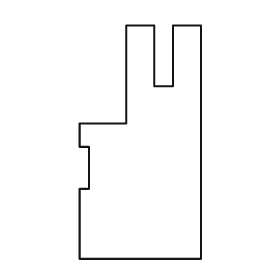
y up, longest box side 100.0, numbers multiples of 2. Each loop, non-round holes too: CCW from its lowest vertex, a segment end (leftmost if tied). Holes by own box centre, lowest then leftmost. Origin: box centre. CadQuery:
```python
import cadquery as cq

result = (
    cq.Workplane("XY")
    .moveTo(-26.0, -50.0)
    .lineTo(26.0, -50.0)
    .lineTo(26.0, 50.0)
    .lineTo(14.0, 50.0)
    .lineTo(14.0, 24.0)
    .lineTo(6.0, 24.0)
    .lineTo(6.0, 50.0)
    .lineTo(-6.0, 50.0)
    .lineTo(-6.0, 8.0)
    .lineTo(-26.0, 8.0)
    .lineTo(-26.0, -2.0)
    .lineTo(-22.0, -2.0)
    .lineTo(-22.0, -20.0)
    .lineTo(-26.0, -20.0)
    .close()
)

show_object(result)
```